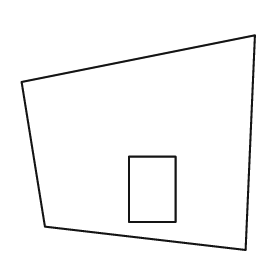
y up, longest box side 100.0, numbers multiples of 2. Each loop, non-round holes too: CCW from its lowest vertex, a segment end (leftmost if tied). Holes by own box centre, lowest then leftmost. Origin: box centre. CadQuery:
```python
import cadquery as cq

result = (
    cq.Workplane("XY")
    .moveTo(46.0, -46.0)
    .lineTo(50.0, 46.0)
    .lineTo(-50.0, 26.0)
    .lineTo(-40.0, -36.0)
    .close()
    .moveTo(-4.0, -34.0)
    .lineTo(16.0, -34.0)
    .lineTo(16.0, -6.0)
    .lineTo(-4.0, -6.0)
    .close()
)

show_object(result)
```